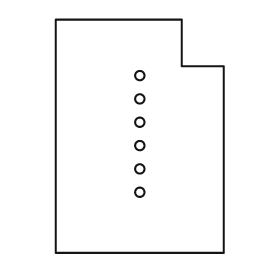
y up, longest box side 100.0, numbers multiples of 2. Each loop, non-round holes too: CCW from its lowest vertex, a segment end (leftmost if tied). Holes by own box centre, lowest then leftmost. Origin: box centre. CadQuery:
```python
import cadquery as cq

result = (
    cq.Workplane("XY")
    .moveTo(-36.0, -50.0)
    .lineTo(36.0, -50.0)
    .lineTo(36.0, 30.0)
    .lineTo(18.0, 30.0)
    .lineTo(18.0, 50.0)
    .lineTo(-36.0, 50.0)
    .close()
    .moveTo(0.0, -24.0)
    .circle(2.0)
    .moveTo(0.0, -14.0)
    .circle(2.0)
    .moveTo(0.0, -4.0)
    .circle(2.0)
    .moveTo(0.0, 6.0)
    .circle(2.0)
    .moveTo(0.0, 16.0)
    .circle(2.0)
    .moveTo(0.0, 26.0)
    .circle(2.0)
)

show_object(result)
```